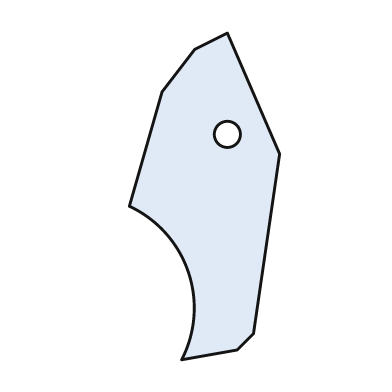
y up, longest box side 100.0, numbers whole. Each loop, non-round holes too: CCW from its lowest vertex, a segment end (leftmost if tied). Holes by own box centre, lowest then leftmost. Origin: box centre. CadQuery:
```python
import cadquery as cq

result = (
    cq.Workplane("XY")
    .moveTo(-7.0, -50.0)
    .lineTo(10.0, -47.0)
    .lineTo(15.0, -42.0)
    .lineTo(23.0, 13.0)
    .lineTo(7.0, 50.0)
    .lineTo(-3.0, 45.0)
    .lineTo(-13.0, 32.0)
    .lineTo(-23.0, -3.0)
    .threePointArc((-5.0, -23.0), (-7.0, -50.0))
    .close()
    .moveTo(7.0, 19.0)
    .circle(4.0)
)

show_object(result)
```